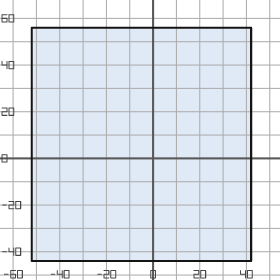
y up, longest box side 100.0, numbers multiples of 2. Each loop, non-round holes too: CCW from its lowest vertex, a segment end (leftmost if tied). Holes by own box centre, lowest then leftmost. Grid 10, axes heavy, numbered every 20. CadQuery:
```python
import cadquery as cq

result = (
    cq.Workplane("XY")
    .moveTo(-52.0, -44.0)
    .lineTo(42.0, -44.0)
    .lineTo(42.0, 56.0)
    .lineTo(-52.0, 56.0)
    .close()
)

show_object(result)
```